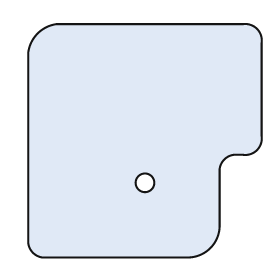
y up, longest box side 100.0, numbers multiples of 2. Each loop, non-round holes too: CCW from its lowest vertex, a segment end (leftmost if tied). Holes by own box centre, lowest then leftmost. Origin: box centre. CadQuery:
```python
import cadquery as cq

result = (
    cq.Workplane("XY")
    .moveTo(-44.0, -50.0)
    .lineTo(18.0, -50.0)
    .threePointArc((28.0, -46.0), (32.0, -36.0))
    .lineTo(32.0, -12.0)
    .threePointArc((34.0, -8.0), (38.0, -6.0))
    .lineTo(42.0, -6.0)
    .threePointArc((48.0, -4.0), (50.0, 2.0))
    .lineTo(50.0, 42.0)
    .threePointArc((48.0, 48.0), (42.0, 50.0))
    .lineTo(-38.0, 50.0)
    .threePointArc((-46.0, 46.0), (-50.0, 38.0))
    .lineTo(-50.0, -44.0)
    .threePointArc((-48.0, -48.0), (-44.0, -50.0))
    .close()
    .moveTo(0.0, -18.0)
    .circle(4.0)
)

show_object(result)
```